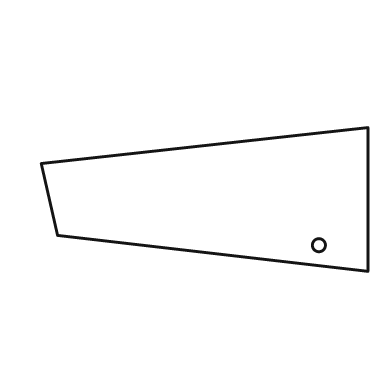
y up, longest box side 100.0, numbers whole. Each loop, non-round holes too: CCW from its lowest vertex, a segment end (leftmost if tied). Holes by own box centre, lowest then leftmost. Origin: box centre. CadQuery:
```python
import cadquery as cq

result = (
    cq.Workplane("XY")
    .moveTo(50.0, -22.0)
    .lineTo(50.0, 22.0)
    .lineTo(-50.0, 11.0)
    .lineTo(-45.0, -11.0)
    .close()
    .moveTo(35.0, -14.0)
    .circle(2.0)
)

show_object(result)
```